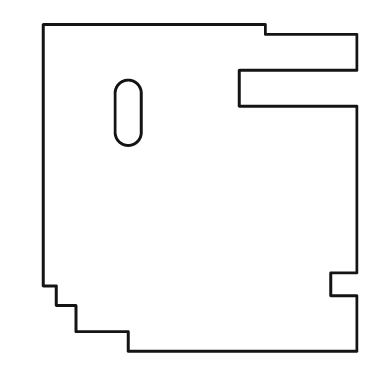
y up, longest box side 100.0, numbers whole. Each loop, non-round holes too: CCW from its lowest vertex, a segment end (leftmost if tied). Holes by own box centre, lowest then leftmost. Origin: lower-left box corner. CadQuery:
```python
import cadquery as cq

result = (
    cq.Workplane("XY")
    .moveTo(26.0, 0.0)
    .lineTo(96.0, 0.0)
    .lineTo(96.0, 17.0)
    .lineTo(88.0, 17.0)
    .lineTo(88.0, 24.0)
    .lineTo(96.0, 24.0)
    .lineTo(96.0, 75.0)
    .lineTo(60.0, 75.0)
    .lineTo(60.0, 86.0)
    .lineTo(96.0, 86.0)
    .lineTo(96.0, 97.0)
    .lineTo(68.0, 97.0)
    .lineTo(68.0, 100.0)
    .lineTo(0.0, 100.0)
    .lineTo(0.0, 20.0)
    .lineTo(4.0, 20.0)
    .lineTo(4.0, 14.0)
    .lineTo(10.0, 14.0)
    .lineTo(10.0, 6.0)
    .lineTo(26.0, 6.0)
    .close()
    .moveTo(22.0, 67.0)
    .threePointArc((26.0, 63.0), (30.0, 67.0))
    .lineTo(30.0, 79.0)
    .threePointArc((26.0, 83.0), (22.0, 79.0))
    .close()
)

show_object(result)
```